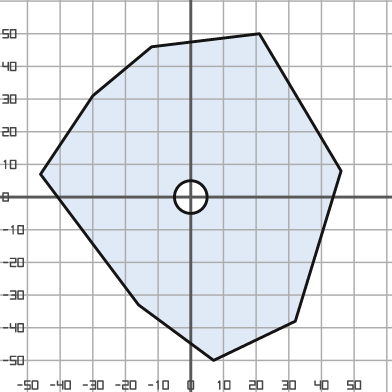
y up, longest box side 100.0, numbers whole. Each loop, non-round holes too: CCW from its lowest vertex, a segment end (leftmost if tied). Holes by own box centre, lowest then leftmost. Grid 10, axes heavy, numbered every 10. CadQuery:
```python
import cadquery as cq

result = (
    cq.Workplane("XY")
    .moveTo(7.0, -50.0)
    .lineTo(32.0, -38.0)
    .lineTo(46.0, 8.0)
    .lineTo(21.0, 50.0)
    .lineTo(-12.0, 46.0)
    .lineTo(-30.0, 31.0)
    .lineTo(-46.0, 7.0)
    .lineTo(-16.0, -33.0)
    .close()
    .moveTo(0.0, 0.0)
    .circle(5.0)
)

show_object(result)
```